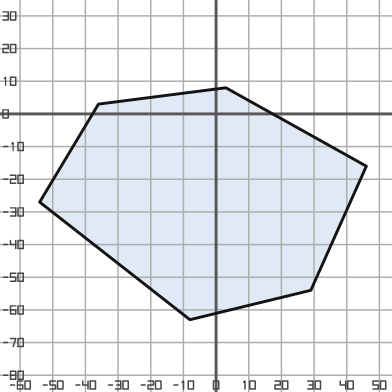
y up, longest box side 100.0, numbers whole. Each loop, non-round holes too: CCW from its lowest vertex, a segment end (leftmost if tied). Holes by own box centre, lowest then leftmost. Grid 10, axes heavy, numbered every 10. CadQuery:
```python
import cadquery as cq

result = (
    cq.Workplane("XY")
    .moveTo(-8.0, -63.0)
    .lineTo(29.0, -54.0)
    .lineTo(46.0, -16.0)
    .lineTo(3.0, 8.0)
    .lineTo(-36.0, 3.0)
    .lineTo(-54.0, -27.0)
    .close()
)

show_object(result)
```